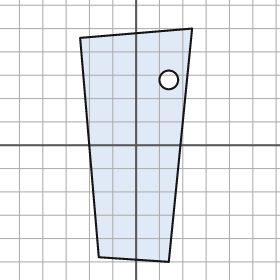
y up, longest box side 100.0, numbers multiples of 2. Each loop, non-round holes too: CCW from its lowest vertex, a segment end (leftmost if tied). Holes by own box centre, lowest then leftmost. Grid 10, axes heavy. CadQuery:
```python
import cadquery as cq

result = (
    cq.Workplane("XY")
    .moveTo(14.0, -50.0)
    .lineTo(24.0, 50.0)
    .lineTo(-24.0, 46.0)
    .lineTo(-16.0, -48.0)
    .close()
    .moveTo(14.0, 28.0)
    .circle(4.0)
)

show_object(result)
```